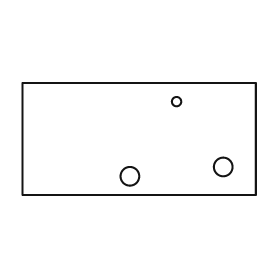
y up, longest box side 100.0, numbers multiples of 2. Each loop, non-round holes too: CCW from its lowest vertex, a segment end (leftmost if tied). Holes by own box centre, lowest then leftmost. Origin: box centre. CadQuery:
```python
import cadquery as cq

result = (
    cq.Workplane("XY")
    .moveTo(-50.0, -24.0)
    .lineTo(50.0, -24.0)
    .lineTo(50.0, 24.0)
    .lineTo(-50.0, 24.0)
    .close()
    .moveTo(-4.0, -16.0)
    .circle(4.0)
    .moveTo(36.0, -12.0)
    .circle(4.0)
    .moveTo(16.0, 16.0)
    .circle(2.0)
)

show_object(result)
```